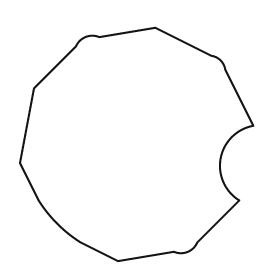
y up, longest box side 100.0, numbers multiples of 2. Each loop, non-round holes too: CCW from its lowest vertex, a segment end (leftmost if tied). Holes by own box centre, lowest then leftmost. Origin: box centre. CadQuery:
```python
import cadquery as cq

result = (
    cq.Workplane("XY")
    .moveTo(-8.0, -50.0)
    .lineTo(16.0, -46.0)
    .threePointArc((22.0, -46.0), (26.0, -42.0))
    .lineTo(44.0, -24.0)
    .threePointArc((36.0, -6.0), (50.0, 8.0))
    .lineTo(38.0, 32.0)
    .threePointArc((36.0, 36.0), (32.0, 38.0))
    .lineTo(8.0, 50.0)
    .lineTo(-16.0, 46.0)
    .threePointArc((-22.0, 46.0), (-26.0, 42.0))
    .lineTo(-44.0, 24.0)
    .lineTo(-50.0, -8.0)
    .lineTo(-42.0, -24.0)
    .threePointArc((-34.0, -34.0), (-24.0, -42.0))
    .close()
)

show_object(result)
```